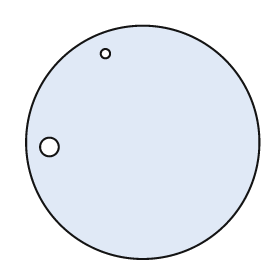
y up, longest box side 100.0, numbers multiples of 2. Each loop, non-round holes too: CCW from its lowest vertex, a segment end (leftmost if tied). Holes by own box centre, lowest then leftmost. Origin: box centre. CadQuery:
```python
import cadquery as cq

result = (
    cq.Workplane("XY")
    .moveTo(0.0, 0.0)
    .circle(50.0)
    .moveTo(-40.0, -2.0)
    .circle(4.0)
    .moveTo(-16.0, 38.0)
    .circle(2.0)
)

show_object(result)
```